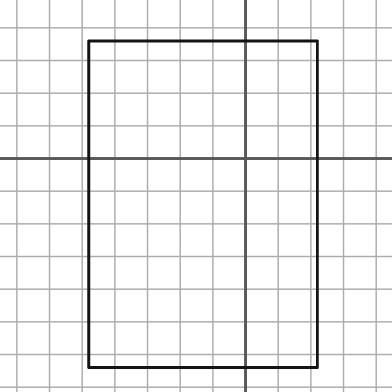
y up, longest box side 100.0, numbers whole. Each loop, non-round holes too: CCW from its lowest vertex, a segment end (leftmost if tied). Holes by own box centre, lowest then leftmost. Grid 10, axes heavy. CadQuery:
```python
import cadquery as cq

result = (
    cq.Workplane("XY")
    .moveTo(-48.0, -64.0)
    .lineTo(22.0, -64.0)
    .lineTo(22.0, 36.0)
    .lineTo(-48.0, 36.0)
    .close()
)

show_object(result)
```